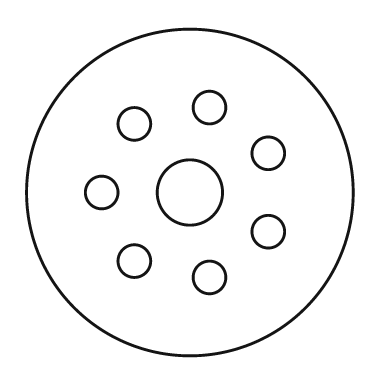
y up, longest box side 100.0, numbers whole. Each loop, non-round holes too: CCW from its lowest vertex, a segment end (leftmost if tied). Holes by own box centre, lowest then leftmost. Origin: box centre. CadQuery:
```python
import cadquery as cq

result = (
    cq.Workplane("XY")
    .moveTo(0.0, 0.0)
    .circle(50.0)
    .moveTo(6.0, -26.0)
    .circle(5.0)
    .moveTo(-17.0, -21.0)
    .circle(5.0)
    .moveTo(24.0, -12.0)
    .circle(5.0)
    .moveTo(-27.0, 0.0)
    .circle(5.0)
    .moveTo(0.0, 0.0)
    .circle(10.0)
    .moveTo(24.0, 12.0)
    .circle(5.0)
    .moveTo(-17.0, 21.0)
    .circle(5.0)
    .moveTo(6.0, 26.0)
    .circle(5.0)
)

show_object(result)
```